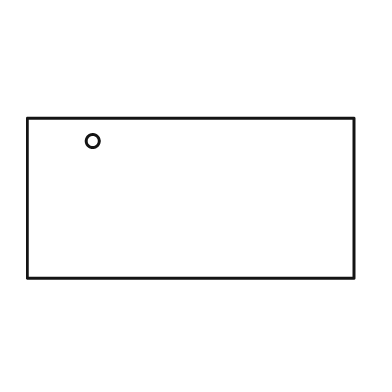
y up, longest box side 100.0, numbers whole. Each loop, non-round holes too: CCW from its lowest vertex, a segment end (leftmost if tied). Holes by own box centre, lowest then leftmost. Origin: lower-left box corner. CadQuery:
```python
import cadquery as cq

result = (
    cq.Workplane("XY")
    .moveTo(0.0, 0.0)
    .lineTo(100.0, 0.0)
    .lineTo(100.0, 49.0)
    .lineTo(0.0, 49.0)
    .close()
    .moveTo(20.0, 42.0)
    .circle(2.0)
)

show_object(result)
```